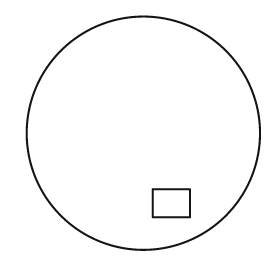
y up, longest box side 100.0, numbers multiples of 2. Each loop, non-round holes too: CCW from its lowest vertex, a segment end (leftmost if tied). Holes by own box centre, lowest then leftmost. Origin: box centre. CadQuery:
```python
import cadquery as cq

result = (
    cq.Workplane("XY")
    .moveTo(0.0, 0.0)
    .circle(50.0)
    .moveTo(4.0, -36.0)
    .lineTo(20.0, -36.0)
    .lineTo(20.0, -24.0)
    .lineTo(4.0, -24.0)
    .close()
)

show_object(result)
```